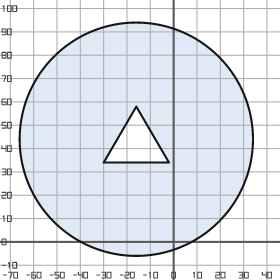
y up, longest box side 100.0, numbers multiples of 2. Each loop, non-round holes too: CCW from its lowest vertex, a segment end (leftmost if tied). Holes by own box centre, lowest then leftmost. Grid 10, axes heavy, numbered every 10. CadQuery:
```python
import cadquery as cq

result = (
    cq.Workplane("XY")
    .moveTo(-16.0, 44.0)
    .circle(50.0)
    .moveTo(-30.0, 34.0)
    .lineTo(-2.0, 34.0)
    .lineTo(-16.0, 58.0)
    .close()
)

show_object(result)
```